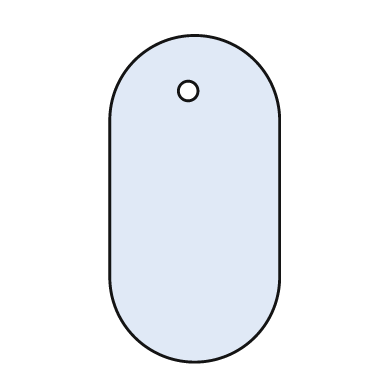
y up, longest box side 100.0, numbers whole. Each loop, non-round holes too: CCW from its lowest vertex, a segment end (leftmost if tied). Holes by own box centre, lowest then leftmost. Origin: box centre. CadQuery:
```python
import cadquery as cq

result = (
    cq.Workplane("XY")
    .moveTo(-26.0, -24.0)
    .threePointArc((0.0, -50.0), (26.0, -24.0))
    .lineTo(26.0, 24.0)
    .threePointArc((0.0, 50.0), (-26.0, 24.0))
    .close()
    .moveTo(-2.0, 33.0)
    .circle(3.0)
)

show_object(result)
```